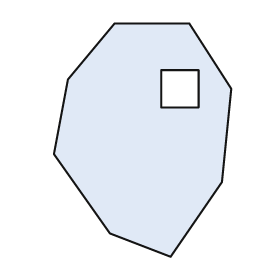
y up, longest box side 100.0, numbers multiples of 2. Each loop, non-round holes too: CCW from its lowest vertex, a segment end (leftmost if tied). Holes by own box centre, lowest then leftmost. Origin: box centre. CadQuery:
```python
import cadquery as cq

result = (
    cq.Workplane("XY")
    .moveTo(12.0, -50.0)
    .lineTo(34.0, -18.0)
    .lineTo(38.0, 22.0)
    .lineTo(20.0, 50.0)
    .lineTo(-12.0, 50.0)
    .lineTo(-32.0, 26.0)
    .lineTo(-38.0, -6.0)
    .lineTo(-14.0, -40.0)
    .close()
    .moveTo(8.0, 14.0)
    .lineTo(24.0, 14.0)
    .lineTo(24.0, 30.0)
    .lineTo(8.0, 30.0)
    .close()
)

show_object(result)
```